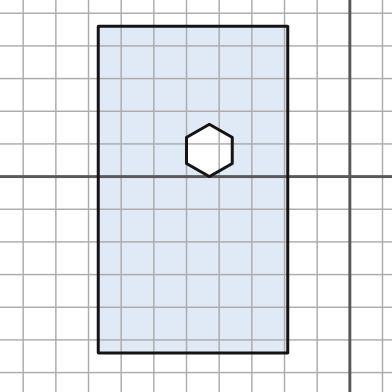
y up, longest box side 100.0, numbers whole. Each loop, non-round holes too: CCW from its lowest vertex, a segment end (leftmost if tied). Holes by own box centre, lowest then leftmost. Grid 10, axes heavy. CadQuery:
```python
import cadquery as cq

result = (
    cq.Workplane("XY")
    .moveTo(-77.0, -54.0)
    .lineTo(-19.0, -54.0)
    .lineTo(-19.0, 46.0)
    .lineTo(-77.0, 46.0)
    .close()
    .moveTo(-43.0, 0.0)
    .lineTo(-36.0, 4.0)
    .lineTo(-36.0, 12.0)
    .lineTo(-43.0, 16.0)
    .lineTo(-50.0, 12.0)
    .lineTo(-50.0, 4.0)
    .close()
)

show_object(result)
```